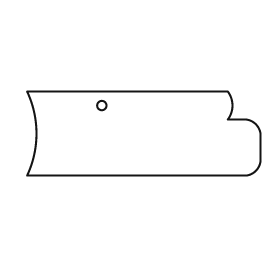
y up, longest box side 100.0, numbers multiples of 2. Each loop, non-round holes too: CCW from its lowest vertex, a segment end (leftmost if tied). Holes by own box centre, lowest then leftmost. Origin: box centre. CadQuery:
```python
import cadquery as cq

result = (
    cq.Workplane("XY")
    .moveTo(-50.0, -18.0)
    .lineTo(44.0, -18.0)
    .threePointArc((48.0, -16.0), (50.0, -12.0))
    .lineTo(50.0, 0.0)
    .threePointArc((48.0, 4.0), (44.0, 6.0))
    .lineTo(36.0, 6.0)
    .threePointArc((38.0, 12.0), (36.0, 18.0))
    .lineTo(-50.0, 18.0)
    .threePointArc((-46.0, 0.0), (-50.0, -18.0))
    .close()
    .moveTo(-18.0, 12.0)
    .circle(2.0)
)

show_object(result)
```